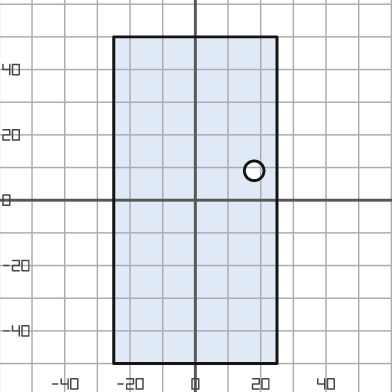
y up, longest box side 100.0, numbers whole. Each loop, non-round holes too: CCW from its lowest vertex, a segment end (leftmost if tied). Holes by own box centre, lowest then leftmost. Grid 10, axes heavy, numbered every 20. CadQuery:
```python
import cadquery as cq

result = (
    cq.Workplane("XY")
    .moveTo(-25.0, -50.0)
    .lineTo(25.0, -50.0)
    .lineTo(25.0, 50.0)
    .lineTo(-25.0, 50.0)
    .close()
    .moveTo(18.0, 9.0)
    .circle(3.0)
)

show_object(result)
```